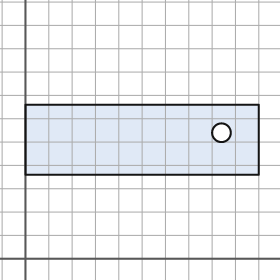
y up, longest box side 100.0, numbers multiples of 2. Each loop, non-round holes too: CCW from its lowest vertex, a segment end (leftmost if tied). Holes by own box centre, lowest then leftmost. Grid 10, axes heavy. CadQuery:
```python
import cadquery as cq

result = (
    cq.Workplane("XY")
    .moveTo(0.0, 36.0)
    .lineTo(100.0, 36.0)
    .lineTo(100.0, 66.0)
    .lineTo(0.0, 66.0)
    .close()
    .moveTo(84.0, 54.0)
    .circle(4.0)
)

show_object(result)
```